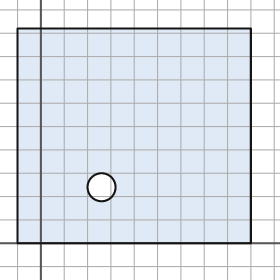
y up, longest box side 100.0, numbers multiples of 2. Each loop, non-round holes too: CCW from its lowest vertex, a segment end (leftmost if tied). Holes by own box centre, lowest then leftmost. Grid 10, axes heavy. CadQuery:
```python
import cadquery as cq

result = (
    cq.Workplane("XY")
    .moveTo(-10.0, 0.0)
    .lineTo(90.0, 0.0)
    .lineTo(90.0, 92.0)
    .lineTo(-10.0, 92.0)
    .close()
    .moveTo(26.0, 24.0)
    .circle(6.0)
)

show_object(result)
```